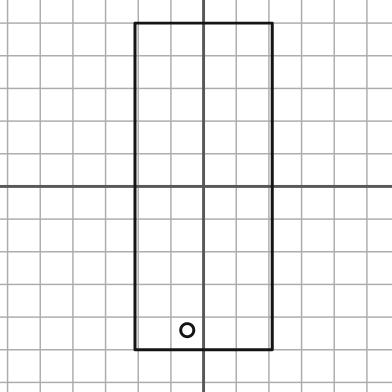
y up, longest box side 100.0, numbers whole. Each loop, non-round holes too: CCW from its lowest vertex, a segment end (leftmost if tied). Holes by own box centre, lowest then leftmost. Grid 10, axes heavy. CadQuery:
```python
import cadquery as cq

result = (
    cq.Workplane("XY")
    .moveTo(-21.0, -50.0)
    .lineTo(21.0, -50.0)
    .lineTo(21.0, 50.0)
    .lineTo(-21.0, 50.0)
    .close()
    .moveTo(-5.0, -44.0)
    .circle(2.0)
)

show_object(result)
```